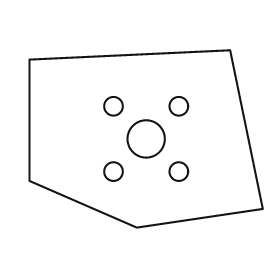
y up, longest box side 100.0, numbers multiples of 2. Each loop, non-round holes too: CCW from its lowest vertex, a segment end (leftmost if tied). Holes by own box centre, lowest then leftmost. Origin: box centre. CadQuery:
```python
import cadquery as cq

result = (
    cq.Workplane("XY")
    .moveTo(-4.0, -38.0)
    .lineTo(50.0, -30.0)
    .lineTo(36.0, 38.0)
    .lineTo(-50.0, 34.0)
    .lineTo(-50.0, -18.0)
    .close()
    .moveTo(-14.0, -14.0)
    .circle(4.0)
    .moveTo(14.0, -14.0)
    .circle(4.0)
    .moveTo(0.0, 0.0)
    .circle(8.0)
    .moveTo(-14.0, 14.0)
    .circle(4.0)
    .moveTo(14.0, 14.0)
    .circle(4.0)
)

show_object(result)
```